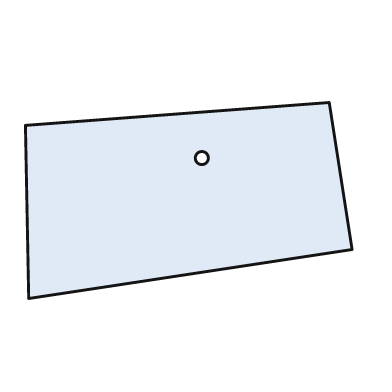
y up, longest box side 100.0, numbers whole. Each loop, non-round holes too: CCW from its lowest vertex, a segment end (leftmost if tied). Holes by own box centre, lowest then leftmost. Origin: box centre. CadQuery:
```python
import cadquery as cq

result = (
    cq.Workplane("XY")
    .moveTo(-49.0, -30.0)
    .lineTo(50.0, -15.0)
    .lineTo(43.0, 30.0)
    .lineTo(-50.0, 23.0)
    .close()
    .moveTo(4.0, 13.0)
    .circle(2.0)
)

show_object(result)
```